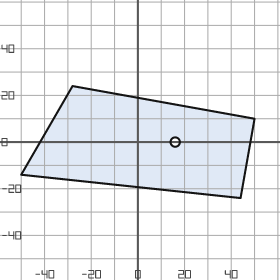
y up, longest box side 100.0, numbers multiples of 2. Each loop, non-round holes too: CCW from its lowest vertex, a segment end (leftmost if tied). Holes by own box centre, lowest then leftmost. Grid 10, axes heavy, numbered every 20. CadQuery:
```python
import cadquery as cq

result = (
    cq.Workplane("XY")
    .moveTo(44.0, -24.0)
    .lineTo(50.0, 10.0)
    .lineTo(-28.0, 24.0)
    .lineTo(-50.0, -14.0)
    .close()
    .moveTo(16.0, 0.0)
    .circle(2.0)
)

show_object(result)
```